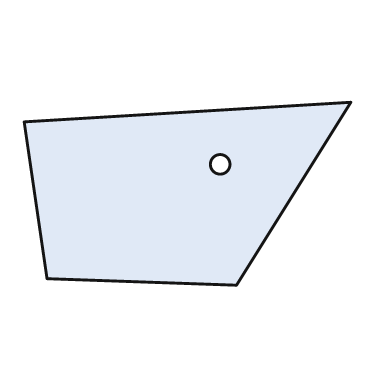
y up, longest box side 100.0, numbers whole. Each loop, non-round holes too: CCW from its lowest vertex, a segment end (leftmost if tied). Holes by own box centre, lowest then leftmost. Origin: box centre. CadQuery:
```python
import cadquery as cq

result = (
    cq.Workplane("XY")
    .moveTo(15.0, -28.0)
    .lineTo(50.0, 28.0)
    .lineTo(-50.0, 22.0)
    .lineTo(-43.0, -26.0)
    .close()
    .moveTo(10.0, 9.0)
    .circle(3.0)
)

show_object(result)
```